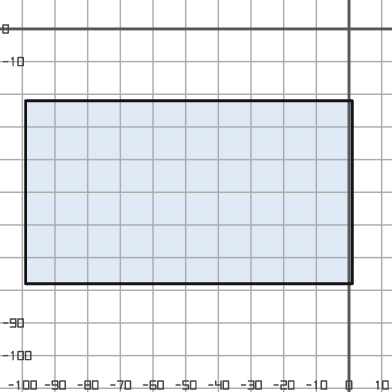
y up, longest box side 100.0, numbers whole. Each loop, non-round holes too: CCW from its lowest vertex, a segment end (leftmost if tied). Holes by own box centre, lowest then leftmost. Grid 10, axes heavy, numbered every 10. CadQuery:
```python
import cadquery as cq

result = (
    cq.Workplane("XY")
    .moveTo(-99.0, -78.0)
    .lineTo(1.0, -78.0)
    .lineTo(1.0, -22.0)
    .lineTo(-99.0, -22.0)
    .close()
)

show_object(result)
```